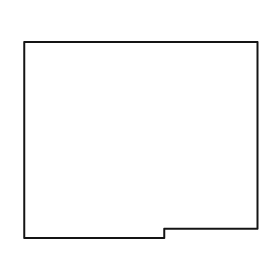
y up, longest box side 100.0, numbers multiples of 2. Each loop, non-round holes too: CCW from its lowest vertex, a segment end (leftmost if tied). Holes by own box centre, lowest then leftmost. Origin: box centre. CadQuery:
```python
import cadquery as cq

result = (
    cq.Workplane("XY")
    .moveTo(-50.0, -42.0)
    .lineTo(10.0, -42.0)
    .lineTo(10.0, -38.0)
    .lineTo(50.0, -38.0)
    .lineTo(50.0, 42.0)
    .lineTo(-50.0, 42.0)
    .close()
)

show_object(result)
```